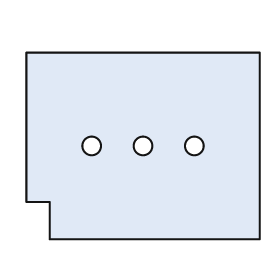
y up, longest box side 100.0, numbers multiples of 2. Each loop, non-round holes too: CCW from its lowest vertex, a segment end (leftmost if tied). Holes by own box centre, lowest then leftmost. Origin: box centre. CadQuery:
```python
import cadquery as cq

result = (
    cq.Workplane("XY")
    .moveTo(-40.0, -40.0)
    .lineTo(50.0, -40.0)
    .lineTo(50.0, 40.0)
    .lineTo(-50.0, 40.0)
    .lineTo(-50.0, -24.0)
    .lineTo(-40.0, -24.0)
    .close()
    .moveTo(-22.0, 0.0)
    .circle(4.0)
    .moveTo(0.0, 0.0)
    .circle(4.0)
    .moveTo(22.0, 0.0)
    .circle(4.0)
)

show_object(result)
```